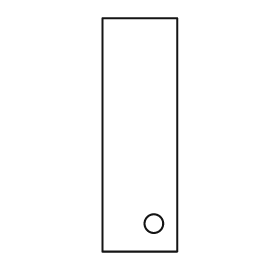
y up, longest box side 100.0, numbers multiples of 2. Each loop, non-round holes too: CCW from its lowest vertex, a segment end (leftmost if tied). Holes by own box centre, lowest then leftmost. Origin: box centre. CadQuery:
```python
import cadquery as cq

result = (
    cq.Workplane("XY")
    .moveTo(-16.0, -50.0)
    .lineTo(16.0, -50.0)
    .lineTo(16.0, 50.0)
    .lineTo(-16.0, 50.0)
    .close()
    .moveTo(6.0, -38.0)
    .circle(4.0)
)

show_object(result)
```